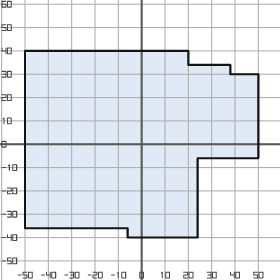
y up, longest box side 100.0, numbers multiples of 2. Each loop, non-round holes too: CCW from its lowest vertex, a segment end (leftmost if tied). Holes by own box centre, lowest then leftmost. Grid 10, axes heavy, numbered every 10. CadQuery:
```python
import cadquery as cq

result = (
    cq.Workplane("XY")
    .moveTo(-6.0, -40.0)
    .lineTo(24.0, -40.0)
    .lineTo(24.0, -6.0)
    .lineTo(50.0, -6.0)
    .lineTo(50.0, 30.0)
    .lineTo(38.0, 30.0)
    .lineTo(38.0, 34.0)
    .lineTo(20.0, 34.0)
    .lineTo(20.0, 40.0)
    .lineTo(-50.0, 40.0)
    .lineTo(-50.0, -36.0)
    .lineTo(-6.0, -36.0)
    .close()
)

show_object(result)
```